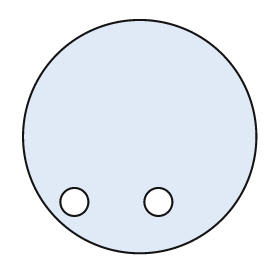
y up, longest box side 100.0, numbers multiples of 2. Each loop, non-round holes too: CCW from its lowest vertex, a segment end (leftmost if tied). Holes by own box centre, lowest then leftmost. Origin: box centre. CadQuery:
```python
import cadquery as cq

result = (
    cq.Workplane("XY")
    .moveTo(0.0, 0.0)
    .circle(50.0)
    .moveTo(-28.0, -28.0)
    .circle(6.0)
    .moveTo(8.0, -28.0)
    .circle(6.0)
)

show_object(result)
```